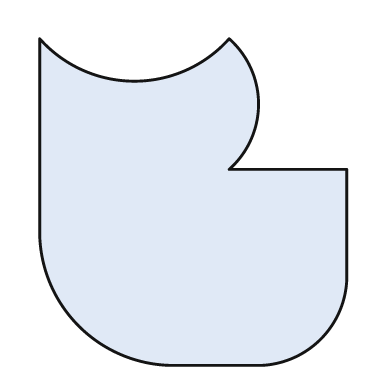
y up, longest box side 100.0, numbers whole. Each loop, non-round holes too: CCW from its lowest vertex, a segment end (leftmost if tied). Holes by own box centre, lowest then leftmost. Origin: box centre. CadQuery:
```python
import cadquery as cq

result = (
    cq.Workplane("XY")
    .moveTo(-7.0, -50.0)
    .lineTo(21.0, -50.0)
    .threePointArc((39.0, -42.0), (47.0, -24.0))
    .lineTo(47.0, 10.0)
    .lineTo(11.0, 10.0)
    .threePointArc((20.0, 30.0), (11.0, 50.0))
    .threePointArc((-18.0, 37.0), (-47.0, 50.0))
    .lineTo(-47.0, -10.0)
    .threePointArc((-35.0, -38.0), (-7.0, -50.0))
    .close()
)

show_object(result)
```